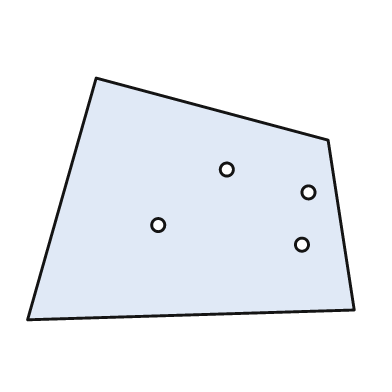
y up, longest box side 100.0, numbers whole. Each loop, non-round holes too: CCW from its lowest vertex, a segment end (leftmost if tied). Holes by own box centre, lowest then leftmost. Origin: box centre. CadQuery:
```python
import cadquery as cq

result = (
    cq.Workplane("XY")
    .moveTo(-50.0, -37.0)
    .lineTo(50.0, -34.0)
    .lineTo(42.0, 18.0)
    .lineTo(-29.0, 37.0)
    .close()
    .moveTo(34.0, -14.0)
    .circle(2.0)
    .moveTo(-10.0, -8.0)
    .circle(2.0)
    .moveTo(36.0, 2.0)
    .circle(2.0)
    .moveTo(11.0, 9.0)
    .circle(2.0)
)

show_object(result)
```